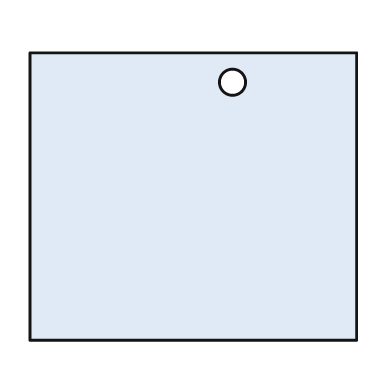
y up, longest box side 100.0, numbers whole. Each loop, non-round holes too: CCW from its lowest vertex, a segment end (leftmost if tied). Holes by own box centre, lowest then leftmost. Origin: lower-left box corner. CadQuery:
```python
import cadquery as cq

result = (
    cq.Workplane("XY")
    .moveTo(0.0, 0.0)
    .lineTo(100.0, 0.0)
    .lineTo(100.0, 88.0)
    .lineTo(0.0, 88.0)
    .close()
    .moveTo(62.0, 79.0)
    .circle(4.0)
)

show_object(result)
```